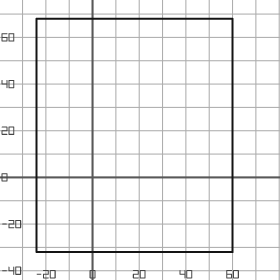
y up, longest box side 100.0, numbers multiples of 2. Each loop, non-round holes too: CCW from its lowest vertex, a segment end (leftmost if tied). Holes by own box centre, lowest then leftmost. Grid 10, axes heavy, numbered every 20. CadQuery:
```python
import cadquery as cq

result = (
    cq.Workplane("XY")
    .moveTo(-24.0, -32.0)
    .lineTo(60.0, -32.0)
    .lineTo(60.0, 68.0)
    .lineTo(-24.0, 68.0)
    .close()
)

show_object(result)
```